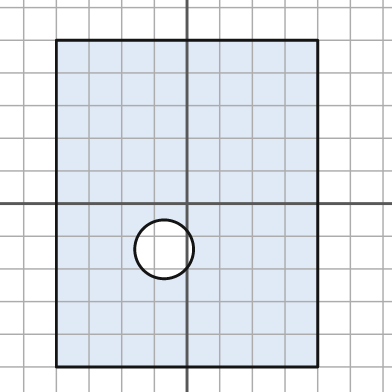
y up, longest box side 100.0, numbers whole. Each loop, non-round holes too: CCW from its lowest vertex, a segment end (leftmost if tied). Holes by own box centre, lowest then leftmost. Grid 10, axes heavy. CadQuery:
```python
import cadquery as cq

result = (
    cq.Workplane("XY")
    .moveTo(-40.0, -50.0)
    .lineTo(40.0, -50.0)
    .lineTo(40.0, 50.0)
    .lineTo(-40.0, 50.0)
    .close()
    .moveTo(-7.0, -14.0)
    .circle(9.0)
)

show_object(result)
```